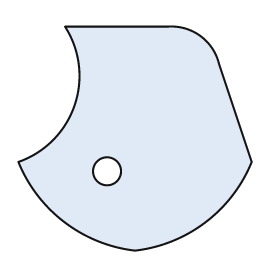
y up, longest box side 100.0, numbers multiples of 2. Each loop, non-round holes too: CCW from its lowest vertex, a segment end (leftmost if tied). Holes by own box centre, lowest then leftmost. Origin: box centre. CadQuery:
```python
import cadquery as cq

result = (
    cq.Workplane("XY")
    .moveTo(0.0, -48.0)
    .threePointArc((30.0, -36.0), (50.0, -10.0))
    .lineTo(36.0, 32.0)
    .threePointArc((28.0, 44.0), (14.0, 48.0))
    .lineTo(-30.0, 48.0)
    .threePointArc((-26.0, 14.0), (-50.0, -10.0))
    .threePointArc((-30.0, -36.0), (0.0, -48.0))
    .close()
    .moveTo(-12.0, -14.0)
    .circle(6.0)
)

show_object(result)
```